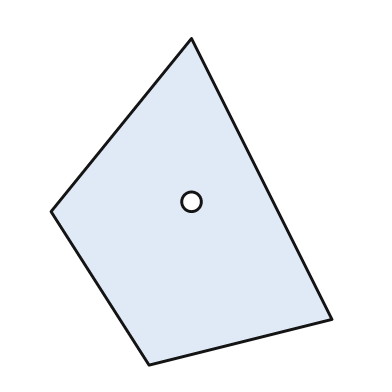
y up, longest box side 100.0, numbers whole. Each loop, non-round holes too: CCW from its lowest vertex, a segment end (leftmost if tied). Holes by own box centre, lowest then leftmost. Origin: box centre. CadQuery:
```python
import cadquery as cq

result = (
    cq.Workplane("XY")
    .moveTo(-13.0, -50.0)
    .lineTo(43.0, -36.0)
    .lineTo(0.0, 50.0)
    .lineTo(-43.0, -3.0)
    .close()
    .moveTo(0.0, 0.0)
    .circle(3.0)
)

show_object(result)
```